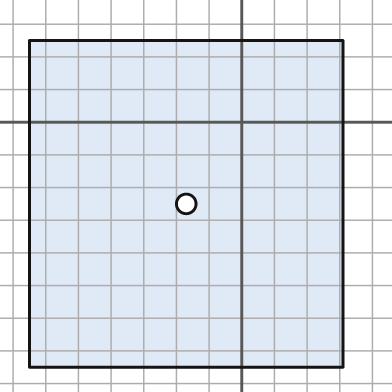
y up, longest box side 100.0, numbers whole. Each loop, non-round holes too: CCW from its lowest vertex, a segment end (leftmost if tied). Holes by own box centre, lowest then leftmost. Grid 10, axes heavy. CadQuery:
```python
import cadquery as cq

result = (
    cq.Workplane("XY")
    .moveTo(-65.0, -75.0)
    .lineTo(31.0, -75.0)
    .lineTo(31.0, 25.0)
    .lineTo(-65.0, 25.0)
    .close()
    .moveTo(-17.0, -25.0)
    .circle(3.0)
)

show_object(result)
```